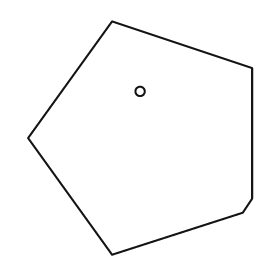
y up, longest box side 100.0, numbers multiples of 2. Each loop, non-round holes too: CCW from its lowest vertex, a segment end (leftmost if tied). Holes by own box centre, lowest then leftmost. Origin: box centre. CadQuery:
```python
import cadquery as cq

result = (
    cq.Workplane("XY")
    .moveTo(-12.0, -50.0)
    .lineTo(44.0, -32.0)
    .lineTo(48.0, -26.0)
    .lineTo(48.0, 30.0)
    .lineTo(-12.0, 50.0)
    .lineTo(-48.0, 0.0)
    .close()
    .moveTo(0.0, 20.0)
    .circle(2.0)
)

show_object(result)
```